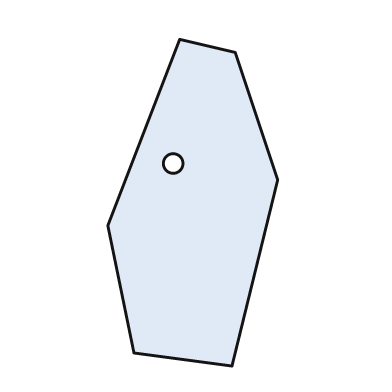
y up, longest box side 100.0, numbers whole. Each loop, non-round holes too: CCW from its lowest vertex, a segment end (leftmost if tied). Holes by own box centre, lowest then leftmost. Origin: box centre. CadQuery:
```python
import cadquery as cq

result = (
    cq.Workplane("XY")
    .moveTo(12.0, -50.0)
    .lineTo(26.0, 7.0)
    .lineTo(13.0, 46.0)
    .lineTo(-4.0, 50.0)
    .lineTo(-26.0, -7.0)
    .lineTo(-18.0, -46.0)
    .close()
    .moveTo(-6.0, 12.0)
    .circle(3.0)
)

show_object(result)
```